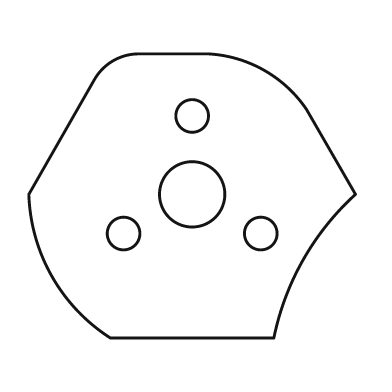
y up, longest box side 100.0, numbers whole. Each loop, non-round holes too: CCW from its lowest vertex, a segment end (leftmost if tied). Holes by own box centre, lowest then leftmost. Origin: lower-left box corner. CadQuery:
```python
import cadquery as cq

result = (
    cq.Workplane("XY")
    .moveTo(25.0, 0.0)
    .lineTo(75.0, 0.0)
    .threePointArc((84.0, 24.0), (100.0, 44.0))
    .lineTo(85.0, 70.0)
    .threePointArc((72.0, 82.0), (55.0, 87.0))
    .lineTo(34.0, 87.0)
    .threePointArc((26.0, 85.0), (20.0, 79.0))
    .lineTo(0.0, 44.0)
    .threePointArc((7.0, 19.0), (25.0, 0.0))
    .close()
    .moveTo(29.0, 32.0)
    .circle(5.0)
    .moveTo(71.0, 32.0)
    .circle(5.0)
    .moveTo(50.0, 44.0)
    .circle(10.0)
    .moveTo(50.0, 68.0)
    .circle(5.0)
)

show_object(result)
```